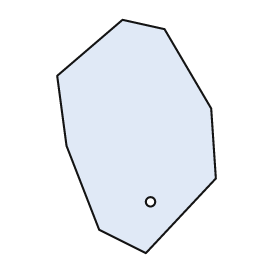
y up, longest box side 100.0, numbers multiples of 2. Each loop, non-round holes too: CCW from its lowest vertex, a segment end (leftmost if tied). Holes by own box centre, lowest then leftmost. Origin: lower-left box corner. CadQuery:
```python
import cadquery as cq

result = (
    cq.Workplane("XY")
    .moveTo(38.0, 0.0)
    .lineTo(68.0, 32.0)
    .lineTo(66.0, 62.0)
    .lineTo(46.0, 96.0)
    .lineTo(28.0, 100.0)
    .lineTo(0.0, 76.0)
    .lineTo(4.0, 46.0)
    .lineTo(18.0, 10.0)
    .close()
    .moveTo(40.0, 22.0)
    .circle(2.0)
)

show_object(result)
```